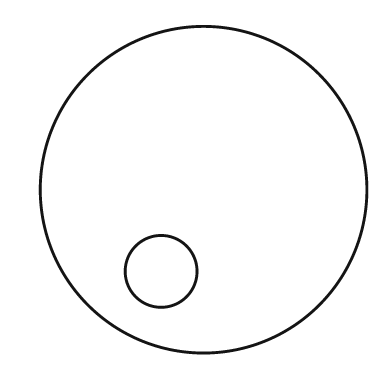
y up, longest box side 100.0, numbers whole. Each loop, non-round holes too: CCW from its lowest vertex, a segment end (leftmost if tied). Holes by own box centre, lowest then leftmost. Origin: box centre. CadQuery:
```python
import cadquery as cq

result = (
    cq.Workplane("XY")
    .moveTo(0.0, 0.0)
    .circle(50.0)
    .moveTo(-13.0, -25.0)
    .circle(11.0)
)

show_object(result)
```